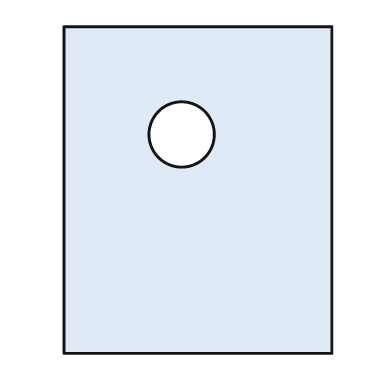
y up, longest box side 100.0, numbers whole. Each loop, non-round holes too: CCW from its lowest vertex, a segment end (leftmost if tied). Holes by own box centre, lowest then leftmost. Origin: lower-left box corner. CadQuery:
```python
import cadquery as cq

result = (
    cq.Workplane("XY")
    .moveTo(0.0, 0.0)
    .lineTo(82.0, 0.0)
    .lineTo(82.0, 100.0)
    .lineTo(0.0, 100.0)
    .close()
    .moveTo(36.0, 67.0)
    .circle(10.0)
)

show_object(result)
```